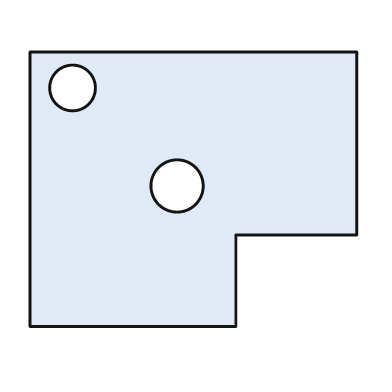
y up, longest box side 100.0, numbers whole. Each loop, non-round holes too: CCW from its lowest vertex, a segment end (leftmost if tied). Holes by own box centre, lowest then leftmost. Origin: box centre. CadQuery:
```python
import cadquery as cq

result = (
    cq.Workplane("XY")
    .moveTo(-50.0, -42.0)
    .lineTo(13.0, -42.0)
    .lineTo(13.0, -14.0)
    .lineTo(50.0, -14.0)
    .lineTo(50.0, 42.0)
    .lineTo(-50.0, 42.0)
    .close()
    .moveTo(-5.0, 1.0)
    .circle(8.0)
    .moveTo(-37.0, 31.0)
    .circle(7.0)
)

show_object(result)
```